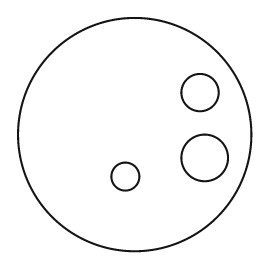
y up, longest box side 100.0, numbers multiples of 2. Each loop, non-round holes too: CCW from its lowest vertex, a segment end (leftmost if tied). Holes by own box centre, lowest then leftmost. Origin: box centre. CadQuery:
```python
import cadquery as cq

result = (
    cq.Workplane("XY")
    .moveTo(0.0, 0.0)
    .circle(50.0)
    .moveTo(-4.0, -18.0)
    .circle(6.0)
    .moveTo(30.0, -10.0)
    .circle(10.0)
    .moveTo(28.0, 18.0)
    .circle(8.0)
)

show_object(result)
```